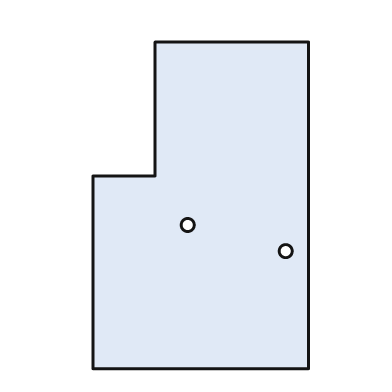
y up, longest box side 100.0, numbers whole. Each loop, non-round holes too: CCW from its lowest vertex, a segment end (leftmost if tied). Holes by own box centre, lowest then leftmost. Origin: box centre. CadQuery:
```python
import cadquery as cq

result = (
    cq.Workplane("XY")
    .moveTo(-33.0, -50.0)
    .lineTo(33.0, -50.0)
    .lineTo(33.0, 50.0)
    .lineTo(-14.0, 50.0)
    .lineTo(-14.0, 9.0)
    .lineTo(-33.0, 9.0)
    .close()
    .moveTo(26.0, -14.0)
    .circle(2.0)
    .moveTo(-4.0, -6.0)
    .circle(2.0)
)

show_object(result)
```